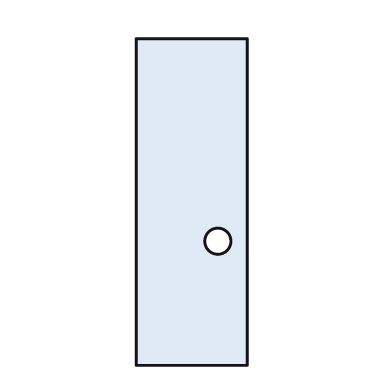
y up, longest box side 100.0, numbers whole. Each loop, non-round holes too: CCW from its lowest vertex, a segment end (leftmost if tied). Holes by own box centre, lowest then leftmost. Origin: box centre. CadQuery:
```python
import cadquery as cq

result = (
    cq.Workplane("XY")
    .moveTo(-17.0, -50.0)
    .lineTo(17.0, -50.0)
    .lineTo(17.0, 50.0)
    .lineTo(-17.0, 50.0)
    .close()
    .moveTo(8.0, -12.0)
    .circle(4.0)
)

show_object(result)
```